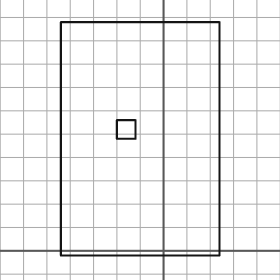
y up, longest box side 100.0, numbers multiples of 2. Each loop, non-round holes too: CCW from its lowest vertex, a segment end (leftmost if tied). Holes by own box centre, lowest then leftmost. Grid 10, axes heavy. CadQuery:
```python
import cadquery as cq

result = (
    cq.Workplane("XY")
    .moveTo(-44.0, -2.0)
    .lineTo(24.0, -2.0)
    .lineTo(24.0, 98.0)
    .lineTo(-44.0, 98.0)
    .close()
    .moveTo(-20.0, 48.0)
    .lineTo(-12.0, 48.0)
    .lineTo(-12.0, 56.0)
    .lineTo(-20.0, 56.0)
    .close()
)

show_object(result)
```